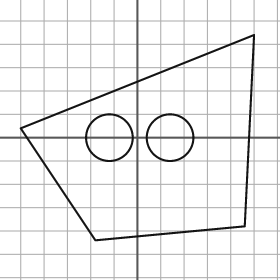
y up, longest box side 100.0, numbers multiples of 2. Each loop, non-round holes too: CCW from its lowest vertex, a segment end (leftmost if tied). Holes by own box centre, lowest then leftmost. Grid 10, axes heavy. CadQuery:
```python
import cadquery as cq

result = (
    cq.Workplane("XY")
    .moveTo(-18.0, -44.0)
    .lineTo(46.0, -38.0)
    .lineTo(50.0, 44.0)
    .lineTo(-50.0, 4.0)
    .close()
    .moveTo(-12.0, 0.0)
    .circle(10.0)
    .moveTo(14.0, 0.0)
    .circle(10.0)
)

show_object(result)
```